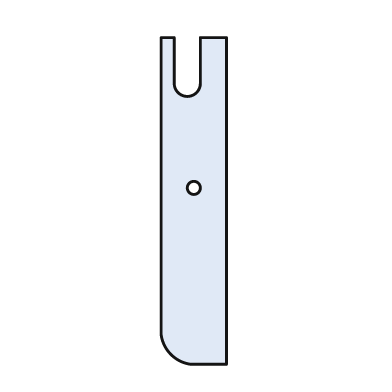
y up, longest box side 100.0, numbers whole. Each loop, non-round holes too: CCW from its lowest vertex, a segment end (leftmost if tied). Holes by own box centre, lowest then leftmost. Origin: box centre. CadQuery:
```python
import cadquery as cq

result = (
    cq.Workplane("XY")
    .moveTo(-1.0, -50.0)
    .lineTo(10.0, -50.0)
    .lineTo(10.0, 50.0)
    .lineTo(2.0, 50.0)
    .lineTo(2.0, 36.0)
    .threePointArc((-2.0, 32.0), (-6.0, 36.0))
    .lineTo(-6.0, 50.0)
    .lineTo(-10.0, 50.0)
    .lineTo(-10.0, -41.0)
    .threePointArc((-7.0, -47.0), (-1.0, -50.0))
    .close()
    .moveTo(0.0, 4.0)
    .circle(2.0)
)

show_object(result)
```